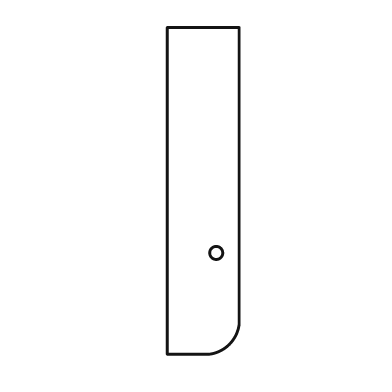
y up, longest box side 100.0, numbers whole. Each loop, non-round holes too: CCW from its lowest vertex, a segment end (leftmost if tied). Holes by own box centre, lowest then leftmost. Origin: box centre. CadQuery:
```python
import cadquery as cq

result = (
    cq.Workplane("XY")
    .moveTo(-11.0, -50.0)
    .lineTo(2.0, -50.0)
    .threePointArc((8.0, -47.0), (11.0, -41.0))
    .lineTo(11.0, 50.0)
    .lineTo(-11.0, 50.0)
    .close()
    .moveTo(4.0, -19.0)
    .circle(2.0)
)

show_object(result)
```